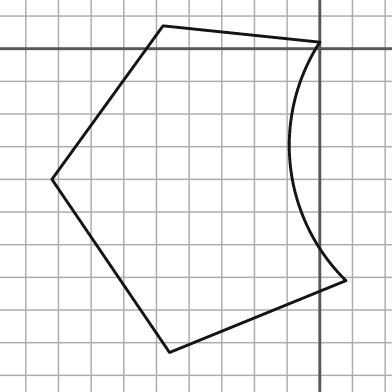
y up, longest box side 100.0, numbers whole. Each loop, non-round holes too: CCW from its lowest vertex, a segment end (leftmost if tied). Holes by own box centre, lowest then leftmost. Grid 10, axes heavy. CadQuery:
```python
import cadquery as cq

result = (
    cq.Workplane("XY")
    .moveTo(-46.0, -93.0)
    .lineTo(8.0, -71.0)
    .threePointArc((-9.0, -36.0), (0.0, 2.0))
    .lineTo(-48.0, 7.0)
    .lineTo(-82.0, -40.0)
    .close()
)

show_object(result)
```